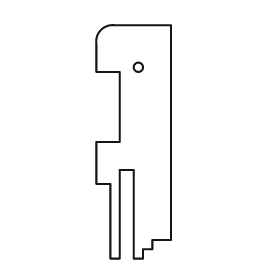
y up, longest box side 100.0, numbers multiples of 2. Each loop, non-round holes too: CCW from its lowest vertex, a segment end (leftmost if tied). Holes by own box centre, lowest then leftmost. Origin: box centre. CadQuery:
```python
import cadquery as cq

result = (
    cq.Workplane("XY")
    .moveTo(-10.0, -50.0)
    .lineTo(-6.0, -50.0)
    .lineTo(-6.0, -12.0)
    .lineTo(0.0, -12.0)
    .lineTo(0.0, -50.0)
    .lineTo(4.0, -50.0)
    .lineTo(4.0, -46.0)
    .lineTo(8.0, -46.0)
    .lineTo(8.0, -42.0)
    .lineTo(16.0, -42.0)
    .lineTo(16.0, 50.0)
    .lineTo(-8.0, 50.0)
    .threePointArc((-14.0, 48.0), (-16.0, 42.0))
    .lineTo(-16.0, 30.0)
    .lineTo(-6.0, 30.0)
    .lineTo(-6.0, 0.0)
    .lineTo(-16.0, 0.0)
    .lineTo(-16.0, -18.0)
    .lineTo(-10.0, -18.0)
    .close()
    .moveTo(2.0, 32.0)
    .circle(2.0)
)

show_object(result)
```